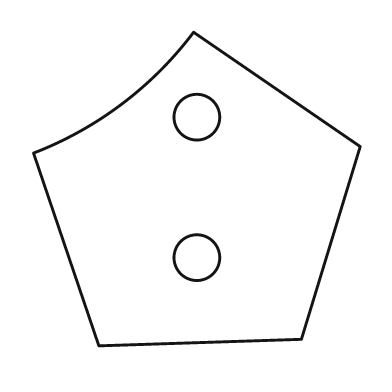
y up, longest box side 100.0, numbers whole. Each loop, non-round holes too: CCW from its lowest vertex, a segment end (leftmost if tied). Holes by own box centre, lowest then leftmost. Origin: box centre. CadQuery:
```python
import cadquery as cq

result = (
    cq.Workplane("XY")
    .moveTo(-30.0, -48.0)
    .lineTo(32.0, -46.0)
    .lineTo(50.0, 13.0)
    .lineTo(-1.0, 48.0)
    .threePointArc((-23.0, 26.0), (-50.0, 11.0))
    .close()
    .moveTo(0.0, -21.0)
    .circle(7.0)
    .moveTo(0.0, 22.0)
    .circle(7.0)
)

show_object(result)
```